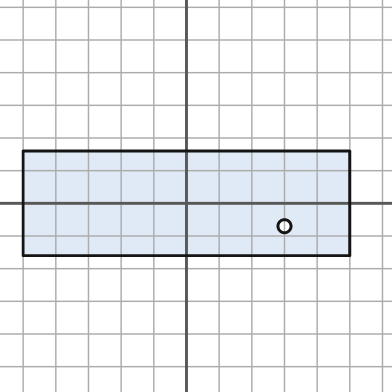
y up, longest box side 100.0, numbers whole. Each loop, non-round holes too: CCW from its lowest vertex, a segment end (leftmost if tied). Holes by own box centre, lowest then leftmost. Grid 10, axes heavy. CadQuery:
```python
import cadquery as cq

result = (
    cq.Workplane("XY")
    .moveTo(-50.0, -16.0)
    .lineTo(50.0, -16.0)
    .lineTo(50.0, 16.0)
    .lineTo(-50.0, 16.0)
    .close()
    .moveTo(30.0, -7.0)
    .circle(2.0)
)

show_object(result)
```